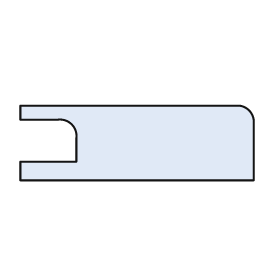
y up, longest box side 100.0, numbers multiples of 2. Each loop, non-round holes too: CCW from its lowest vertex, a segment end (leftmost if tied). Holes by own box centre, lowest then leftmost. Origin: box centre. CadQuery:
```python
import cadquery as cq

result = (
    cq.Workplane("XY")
    .moveTo(-50.0, -16.0)
    .lineTo(50.0, -16.0)
    .lineTo(50.0, 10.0)
    .threePointArc((48.0, 14.0), (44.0, 16.0))
    .lineTo(-50.0, 16.0)
    .lineTo(-50.0, 10.0)
    .lineTo(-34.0, 10.0)
    .threePointArc((-28.0, 8.0), (-26.0, 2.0))
    .lineTo(-26.0, -8.0)
    .lineTo(-50.0, -8.0)
    .close()
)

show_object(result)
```